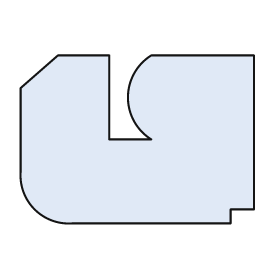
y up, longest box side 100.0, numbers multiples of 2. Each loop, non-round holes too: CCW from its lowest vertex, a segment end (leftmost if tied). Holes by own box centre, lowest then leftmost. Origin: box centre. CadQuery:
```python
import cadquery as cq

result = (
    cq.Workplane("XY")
    .moveTo(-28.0, -36.0)
    .lineTo(40.0, -36.0)
    .lineTo(40.0, -30.0)
    .lineTo(50.0, -30.0)
    .lineTo(50.0, 36.0)
    .lineTo(6.0, 36.0)
    .threePointArc((-4.0, 18.0), (6.0, 0.0))
    .lineTo(-12.0, 0.0)
    .lineTo(-12.0, 36.0)
    .lineTo(-34.0, 36.0)
    .lineTo(-50.0, 22.0)
    .lineTo(-50.0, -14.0)
    .threePointArc((-44.0, -30.0), (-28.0, -36.0))
    .close()
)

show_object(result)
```